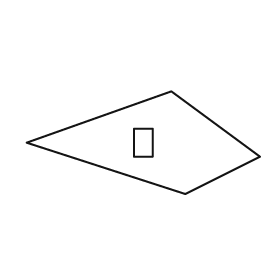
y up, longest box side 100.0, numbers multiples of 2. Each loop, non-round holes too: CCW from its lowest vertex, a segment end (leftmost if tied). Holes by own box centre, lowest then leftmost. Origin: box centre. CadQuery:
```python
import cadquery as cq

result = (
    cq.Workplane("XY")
    .moveTo(18.0, -22.0)
    .lineTo(50.0, -6.0)
    .lineTo(12.0, 22.0)
    .lineTo(-50.0, 0.0)
    .close()
    .moveTo(-4.0, -6.0)
    .lineTo(4.0, -6.0)
    .lineTo(4.0, 6.0)
    .lineTo(-4.0, 6.0)
    .close()
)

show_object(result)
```